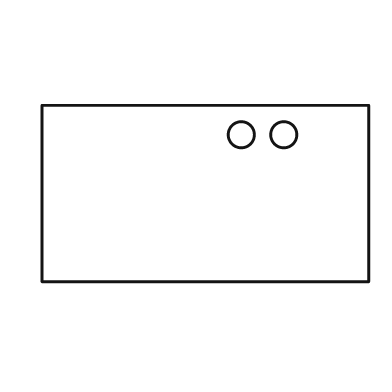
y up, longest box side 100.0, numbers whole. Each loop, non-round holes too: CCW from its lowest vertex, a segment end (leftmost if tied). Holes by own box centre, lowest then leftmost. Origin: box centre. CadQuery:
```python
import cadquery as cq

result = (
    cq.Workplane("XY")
    .moveTo(-50.0, -27.0)
    .lineTo(50.0, -27.0)
    .lineTo(50.0, 27.0)
    .lineTo(-50.0, 27.0)
    .close()
    .moveTo(11.0, 18.0)
    .circle(4.0)
    .moveTo(24.0, 18.0)
    .circle(4.0)
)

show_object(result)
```